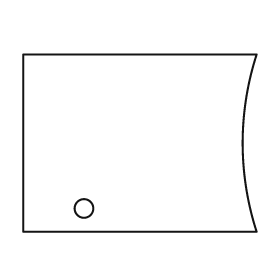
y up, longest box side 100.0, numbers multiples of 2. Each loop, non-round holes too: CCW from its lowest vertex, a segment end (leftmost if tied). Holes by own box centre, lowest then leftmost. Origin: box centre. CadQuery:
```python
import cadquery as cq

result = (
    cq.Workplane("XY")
    .moveTo(-50.0, -38.0)
    .lineTo(50.0, -38.0)
    .threePointArc((44.0, 0.0), (50.0, 38.0))
    .lineTo(-50.0, 38.0)
    .close()
    .moveTo(-24.0, -28.0)
    .circle(4.0)
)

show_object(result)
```